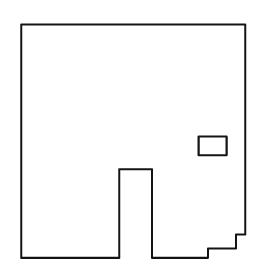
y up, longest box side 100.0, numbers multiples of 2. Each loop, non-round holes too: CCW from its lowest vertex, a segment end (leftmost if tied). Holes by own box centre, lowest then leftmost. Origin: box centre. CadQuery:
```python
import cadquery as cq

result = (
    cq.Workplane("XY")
    .moveTo(-48.0, -50.0)
    .lineTo(-6.0, -50.0)
    .lineTo(-6.0, -12.0)
    .lineTo(8.0, -12.0)
    .lineTo(8.0, -50.0)
    .lineTo(32.0, -50.0)
    .lineTo(32.0, -46.0)
    .lineTo(44.0, -46.0)
    .lineTo(44.0, -40.0)
    .lineTo(48.0, -40.0)
    .lineTo(48.0, 50.0)
    .lineTo(-48.0, 50.0)
    .close()
    .moveTo(28.0, -6.0)
    .lineTo(40.0, -6.0)
    .lineTo(40.0, 2.0)
    .lineTo(28.0, 2.0)
    .close()
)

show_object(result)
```